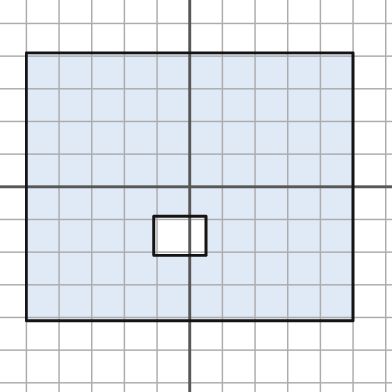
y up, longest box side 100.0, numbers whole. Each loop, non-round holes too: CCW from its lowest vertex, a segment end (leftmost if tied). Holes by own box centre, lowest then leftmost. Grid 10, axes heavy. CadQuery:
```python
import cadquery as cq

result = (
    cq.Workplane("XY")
    .moveTo(-50.0, -41.0)
    .lineTo(50.0, -41.0)
    .lineTo(50.0, 41.0)
    .lineTo(-50.0, 41.0)
    .close()
    .moveTo(-11.0, -21.0)
    .lineTo(5.0, -21.0)
    .lineTo(5.0, -9.0)
    .lineTo(-11.0, -9.0)
    .close()
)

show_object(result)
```